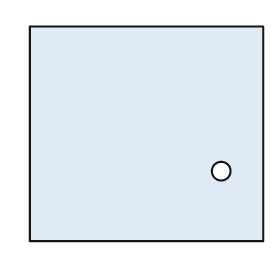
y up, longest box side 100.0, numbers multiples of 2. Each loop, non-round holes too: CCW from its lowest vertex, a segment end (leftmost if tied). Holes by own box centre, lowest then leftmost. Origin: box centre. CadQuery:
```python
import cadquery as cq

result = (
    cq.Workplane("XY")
    .moveTo(-50.0, -46.0)
    .lineTo(50.0, -46.0)
    .lineTo(50.0, 46.0)
    .lineTo(-50.0, 46.0)
    .close()
    .moveTo(32.0, -16.0)
    .circle(4.0)
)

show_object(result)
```